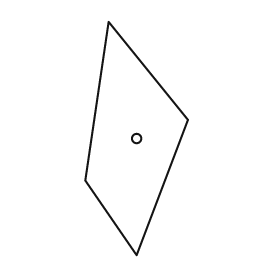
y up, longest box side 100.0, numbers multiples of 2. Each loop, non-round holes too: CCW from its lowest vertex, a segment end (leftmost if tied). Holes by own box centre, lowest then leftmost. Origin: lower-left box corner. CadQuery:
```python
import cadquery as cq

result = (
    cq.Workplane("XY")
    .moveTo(22.0, 0.0)
    .lineTo(44.0, 58.0)
    .lineTo(10.0, 100.0)
    .lineTo(0.0, 32.0)
    .close()
    .moveTo(22.0, 50.0)
    .circle(2.0)
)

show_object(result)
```